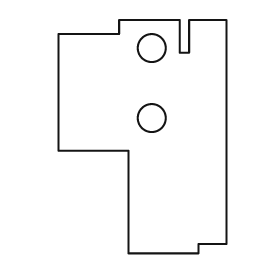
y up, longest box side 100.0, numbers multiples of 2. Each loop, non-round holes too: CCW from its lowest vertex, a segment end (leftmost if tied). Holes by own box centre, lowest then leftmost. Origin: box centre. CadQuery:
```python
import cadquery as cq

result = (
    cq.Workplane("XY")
    .moveTo(-6.0, -50.0)
    .lineTo(24.0, -50.0)
    .lineTo(24.0, -46.0)
    .lineTo(36.0, -46.0)
    .lineTo(36.0, 50.0)
    .lineTo(20.0, 50.0)
    .lineTo(20.0, 36.0)
    .lineTo(16.0, 36.0)
    .lineTo(16.0, 50.0)
    .lineTo(-10.0, 50.0)
    .lineTo(-10.0, 44.0)
    .lineTo(-36.0, 44.0)
    .lineTo(-36.0, -6.0)
    .lineTo(-6.0, -6.0)
    .close()
    .moveTo(4.0, 8.0)
    .circle(6.0)
    .moveTo(4.0, 38.0)
    .circle(6.0)
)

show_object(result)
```